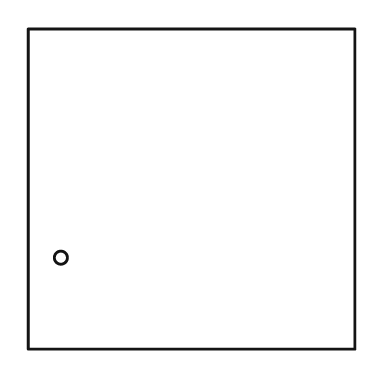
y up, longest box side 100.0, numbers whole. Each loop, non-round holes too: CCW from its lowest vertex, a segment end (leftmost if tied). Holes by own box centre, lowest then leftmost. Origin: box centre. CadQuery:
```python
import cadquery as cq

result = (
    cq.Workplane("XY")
    .moveTo(-50.0, -49.0)
    .lineTo(50.0, -49.0)
    .lineTo(50.0, 49.0)
    .lineTo(-50.0, 49.0)
    .close()
    .moveTo(-40.0, -21.0)
    .circle(2.0)
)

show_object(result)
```